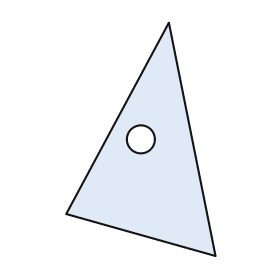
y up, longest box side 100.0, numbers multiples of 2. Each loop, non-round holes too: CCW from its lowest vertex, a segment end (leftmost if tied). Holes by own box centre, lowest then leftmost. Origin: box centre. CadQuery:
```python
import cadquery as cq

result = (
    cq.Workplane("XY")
    .moveTo(32.0, -50.0)
    .lineTo(12.0, 50.0)
    .lineTo(-32.0, -32.0)
    .close()
    .moveTo(0.0, 0.0)
    .circle(6.0)
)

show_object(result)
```